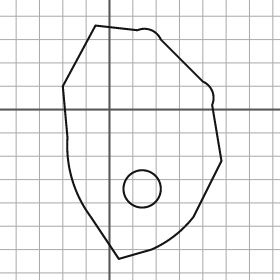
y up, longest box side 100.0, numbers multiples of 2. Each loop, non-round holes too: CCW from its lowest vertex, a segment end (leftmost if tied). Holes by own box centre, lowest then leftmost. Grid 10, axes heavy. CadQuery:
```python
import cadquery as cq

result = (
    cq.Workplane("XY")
    .moveTo(4.0, -64.0)
    .lineTo(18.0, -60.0)
    .threePointArc((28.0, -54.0), (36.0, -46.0))
    .lineTo(48.0, -22.0)
    .lineTo(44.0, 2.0)
    .threePointArc((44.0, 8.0), (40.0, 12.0))
    .lineTo(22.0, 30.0)
    .threePointArc((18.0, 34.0), (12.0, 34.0))
    .lineTo(-6.0, 36.0)
    .lineTo(-20.0, 10.0)
    .lineTo(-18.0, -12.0)
    .threePointArc((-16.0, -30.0), (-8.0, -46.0))
    .close()
    .moveTo(14.0, -34.0)
    .circle(8.0)
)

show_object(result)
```